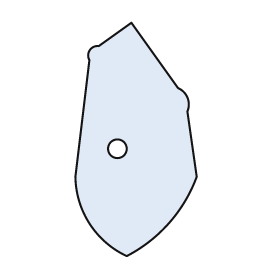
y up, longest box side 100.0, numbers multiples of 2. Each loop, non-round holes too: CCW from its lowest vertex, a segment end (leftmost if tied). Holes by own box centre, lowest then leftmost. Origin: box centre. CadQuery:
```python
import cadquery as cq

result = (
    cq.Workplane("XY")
    .moveTo(-4.0, -50.0)
    .threePointArc((14.0, -36.0), (26.0, -16.0))
    .lineTo(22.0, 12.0)
    .threePointArc((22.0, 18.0), (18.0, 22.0))
    .lineTo(-2.0, 50.0)
    .lineTo(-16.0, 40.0)
    .threePointArc((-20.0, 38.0), (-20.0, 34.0))
    .lineTo(-26.0, -16.0)
    .threePointArc((-20.0, -36.0), (-4.0, -50.0))
    .close()
    .moveTo(-8.0, -4.0)
    .circle(4.0)
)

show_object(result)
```